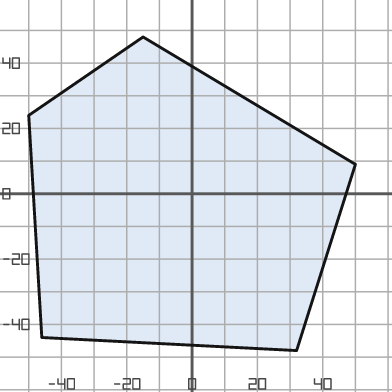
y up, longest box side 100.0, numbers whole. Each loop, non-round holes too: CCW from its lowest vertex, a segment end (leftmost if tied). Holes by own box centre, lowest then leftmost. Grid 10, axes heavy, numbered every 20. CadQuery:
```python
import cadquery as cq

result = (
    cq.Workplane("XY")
    .moveTo(32.0, -48.0)
    .lineTo(50.0, 9.0)
    .lineTo(-15.0, 48.0)
    .lineTo(-50.0, 24.0)
    .lineTo(-46.0, -44.0)
    .close()
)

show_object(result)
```